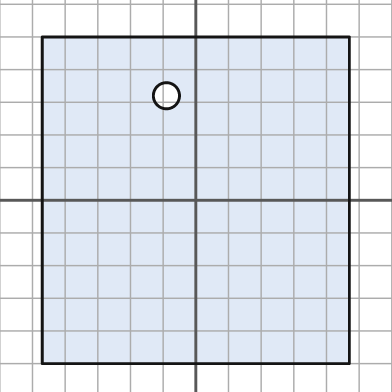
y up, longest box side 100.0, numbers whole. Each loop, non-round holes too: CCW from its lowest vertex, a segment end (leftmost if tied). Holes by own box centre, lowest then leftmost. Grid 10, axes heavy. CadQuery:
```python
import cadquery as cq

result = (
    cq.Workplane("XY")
    .moveTo(-47.0, -50.0)
    .lineTo(47.0, -50.0)
    .lineTo(47.0, 50.0)
    .lineTo(-47.0, 50.0)
    .close()
    .moveTo(-9.0, 32.0)
    .circle(4.0)
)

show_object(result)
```